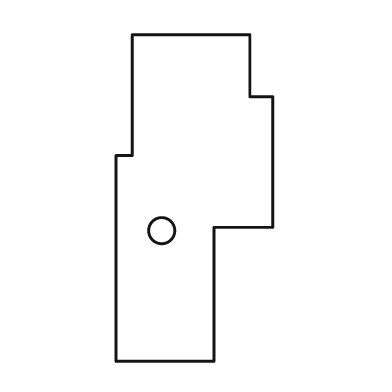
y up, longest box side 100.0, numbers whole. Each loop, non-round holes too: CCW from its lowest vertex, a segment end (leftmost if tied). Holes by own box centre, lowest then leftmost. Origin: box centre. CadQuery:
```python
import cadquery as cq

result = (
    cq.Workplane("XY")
    .moveTo(-24.0, -50.0)
    .lineTo(6.0, -50.0)
    .lineTo(6.0, -9.0)
    .lineTo(24.0, -9.0)
    .lineTo(24.0, 31.0)
    .lineTo(17.0, 31.0)
    .lineTo(17.0, 50.0)
    .lineTo(-19.0, 50.0)
    .lineTo(-19.0, 13.0)
    .lineTo(-24.0, 13.0)
    .close()
    .moveTo(-10.0, -10.0)
    .circle(4.0)
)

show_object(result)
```